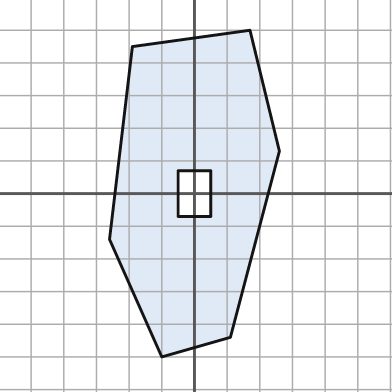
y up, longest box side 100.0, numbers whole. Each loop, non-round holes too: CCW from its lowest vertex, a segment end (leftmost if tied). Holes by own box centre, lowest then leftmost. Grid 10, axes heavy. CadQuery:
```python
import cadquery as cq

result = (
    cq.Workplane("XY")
    .moveTo(-10.0, -50.0)
    .lineTo(11.0, -44.0)
    .lineTo(26.0, 13.0)
    .lineTo(17.0, 50.0)
    .lineTo(-19.0, 45.0)
    .lineTo(-26.0, -14.0)
    .close()
    .moveTo(-5.0, -7.0)
    .lineTo(5.0, -7.0)
    .lineTo(5.0, 7.0)
    .lineTo(-5.0, 7.0)
    .close()
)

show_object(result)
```